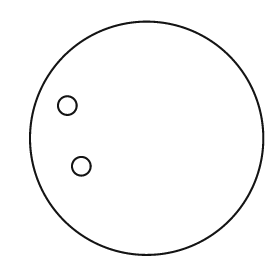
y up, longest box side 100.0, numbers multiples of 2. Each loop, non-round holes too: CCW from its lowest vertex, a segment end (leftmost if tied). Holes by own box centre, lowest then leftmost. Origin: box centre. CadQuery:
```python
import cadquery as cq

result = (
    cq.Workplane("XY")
    .moveTo(0.0, 0.0)
    .circle(50.0)
    .moveTo(-28.0, -12.0)
    .circle(4.0)
    .moveTo(-34.0, 14.0)
    .circle(4.0)
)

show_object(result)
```